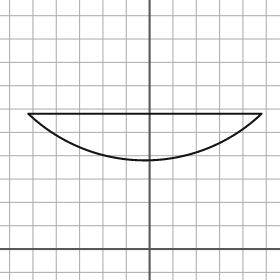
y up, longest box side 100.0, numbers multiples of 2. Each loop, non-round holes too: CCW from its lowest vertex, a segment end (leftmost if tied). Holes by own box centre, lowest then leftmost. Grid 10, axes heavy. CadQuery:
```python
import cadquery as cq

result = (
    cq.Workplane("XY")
    .moveTo(-52.0, 58.0)
    .threePointArc((-2.0, 38.0), (48.0, 58.0))
    .close()
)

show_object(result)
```